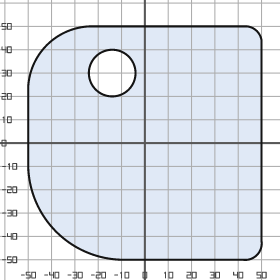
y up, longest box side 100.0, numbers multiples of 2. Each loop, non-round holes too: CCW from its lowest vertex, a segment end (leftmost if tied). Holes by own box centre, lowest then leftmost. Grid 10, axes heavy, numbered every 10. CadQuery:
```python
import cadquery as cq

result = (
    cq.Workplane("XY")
    .moveTo(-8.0, -50.0)
    .lineTo(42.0, -50.0)
    .threePointArc((48.0, -48.0), (50.0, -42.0))
    .lineTo(50.0, 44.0)
    .threePointArc((48.0, 48.0), (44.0, 50.0))
    .lineTo(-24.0, 50.0)
    .threePointArc((-42.0, 42.0), (-50.0, 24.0))
    .lineTo(-50.0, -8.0)
    .threePointArc((-38.0, -38.0), (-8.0, -50.0))
    .close()
    .moveTo(-14.0, 30.0)
    .circle(10.0)
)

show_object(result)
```